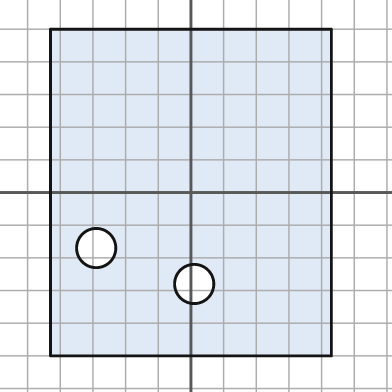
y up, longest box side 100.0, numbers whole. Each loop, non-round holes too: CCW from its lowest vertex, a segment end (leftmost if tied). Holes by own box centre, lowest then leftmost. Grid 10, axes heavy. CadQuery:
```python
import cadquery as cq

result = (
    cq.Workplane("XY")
    .moveTo(-43.0, -50.0)
    .lineTo(43.0, -50.0)
    .lineTo(43.0, 50.0)
    .lineTo(-43.0, 50.0)
    .close()
    .moveTo(1.0, -28.0)
    .circle(6.0)
    .moveTo(-29.0, -17.0)
    .circle(6.0)
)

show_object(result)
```